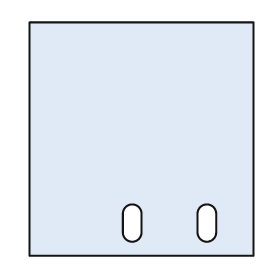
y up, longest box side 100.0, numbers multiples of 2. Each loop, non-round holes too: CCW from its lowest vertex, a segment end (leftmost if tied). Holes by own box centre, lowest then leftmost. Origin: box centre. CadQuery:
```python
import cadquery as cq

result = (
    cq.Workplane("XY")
    .moveTo(-48.0, -50.0)
    .lineTo(48.0, -50.0)
    .lineTo(48.0, 50.0)
    .lineTo(-48.0, 50.0)
    .close()
    .moveTo(-8.0, -40.0)
    .threePointArc((-4.0, -44.0), (0.0, -40.0))
    .lineTo(0.0, -32.0)
    .threePointArc((-4.0, -28.0), (-8.0, -32.0))
    .close()
    .moveTo(24.0, -40.0)
    .threePointArc((28.0, -44.0), (32.0, -40.0))
    .lineTo(32.0, -32.0)
    .threePointArc((28.0, -28.0), (24.0, -32.0))
    .close()
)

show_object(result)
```